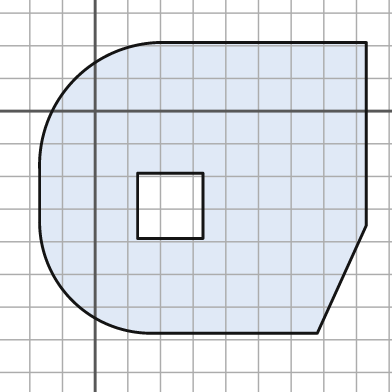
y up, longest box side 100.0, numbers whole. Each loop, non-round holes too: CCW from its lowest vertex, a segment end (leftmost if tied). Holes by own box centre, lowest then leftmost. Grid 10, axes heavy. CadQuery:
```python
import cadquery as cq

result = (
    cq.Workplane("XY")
    .moveTo(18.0, -68.0)
    .lineTo(68.0, -68.0)
    .lineTo(83.0, -35.0)
    .lineTo(83.0, 21.0)
    .lineTo(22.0, 21.0)
    .threePointArc((-6.0, 10.0), (-17.0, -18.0))
    .lineTo(-17.0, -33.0)
    .threePointArc((-7.0, -58.0), (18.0, -68.0))
    .close()
    .moveTo(13.0, -39.0)
    .lineTo(33.0, -39.0)
    .lineTo(33.0, -19.0)
    .lineTo(13.0, -19.0)
    .close()
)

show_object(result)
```